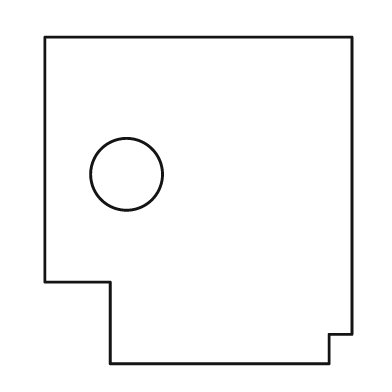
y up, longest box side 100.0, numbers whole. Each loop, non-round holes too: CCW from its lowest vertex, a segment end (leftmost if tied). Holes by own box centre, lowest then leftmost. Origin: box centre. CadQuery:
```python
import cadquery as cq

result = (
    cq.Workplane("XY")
    .moveTo(-27.0, -50.0)
    .lineTo(40.0, -50.0)
    .lineTo(40.0, -41.0)
    .lineTo(47.0, -41.0)
    .lineTo(47.0, 50.0)
    .lineTo(-47.0, 50.0)
    .lineTo(-47.0, -25.0)
    .lineTo(-27.0, -25.0)
    .close()
    .moveTo(-22.0, 8.0)
    .circle(11.0)
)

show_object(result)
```